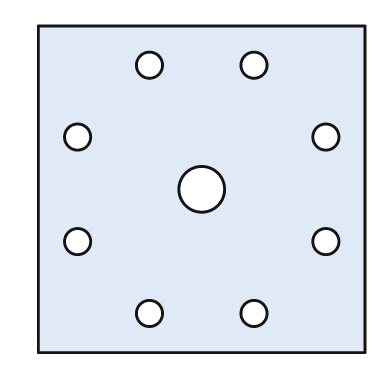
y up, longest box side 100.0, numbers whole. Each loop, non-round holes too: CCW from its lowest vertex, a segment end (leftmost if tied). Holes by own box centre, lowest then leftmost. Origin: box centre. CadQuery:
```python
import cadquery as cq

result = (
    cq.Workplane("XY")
    .moveTo(-50.0, -50.0)
    .lineTo(50.0, -50.0)
    .lineTo(50.0, 50.0)
    .lineTo(-50.0, 50.0)
    .close()
    .moveTo(-16.0, -38.0)
    .circle(4.0)
    .moveTo(16.0, -38.0)
    .circle(4.0)
    .moveTo(-38.0, -16.0)
    .circle(4.0)
    .moveTo(38.0, -16.0)
    .circle(4.0)
    .moveTo(0.0, 0.0)
    .circle(7.0)
    .moveTo(-38.0, 16.0)
    .circle(4.0)
    .moveTo(38.0, 16.0)
    .circle(4.0)
    .moveTo(-16.0, 38.0)
    .circle(4.0)
    .moveTo(16.0, 38.0)
    .circle(4.0)
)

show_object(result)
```